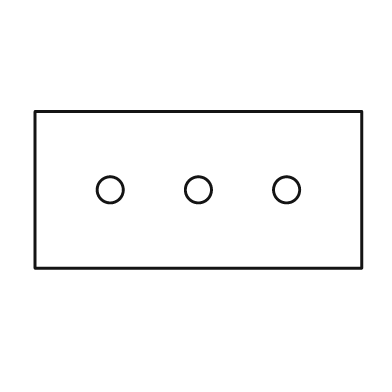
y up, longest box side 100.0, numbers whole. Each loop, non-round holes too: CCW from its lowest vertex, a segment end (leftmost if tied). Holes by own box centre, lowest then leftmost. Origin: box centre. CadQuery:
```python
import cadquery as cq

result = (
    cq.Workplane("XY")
    .moveTo(-50.0, -24.0)
    .lineTo(50.0, -24.0)
    .lineTo(50.0, 24.0)
    .lineTo(-50.0, 24.0)
    .close()
    .moveTo(-27.0, 0.0)
    .circle(4.0)
    .moveTo(0.0, 0.0)
    .circle(4.0)
    .moveTo(27.0, 0.0)
    .circle(4.0)
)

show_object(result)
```